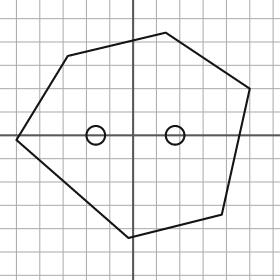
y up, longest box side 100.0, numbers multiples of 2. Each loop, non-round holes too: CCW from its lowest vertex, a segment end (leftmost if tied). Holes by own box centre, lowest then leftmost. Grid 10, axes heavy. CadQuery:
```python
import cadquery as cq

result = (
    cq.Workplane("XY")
    .moveTo(-2.0, -44.0)
    .lineTo(38.0, -34.0)
    .lineTo(50.0, 20.0)
    .lineTo(14.0, 44.0)
    .lineTo(-28.0, 34.0)
    .lineTo(-50.0, -2.0)
    .close()
    .moveTo(-16.0, 0.0)
    .circle(4.0)
    .moveTo(18.0, 0.0)
    .circle(4.0)
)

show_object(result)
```